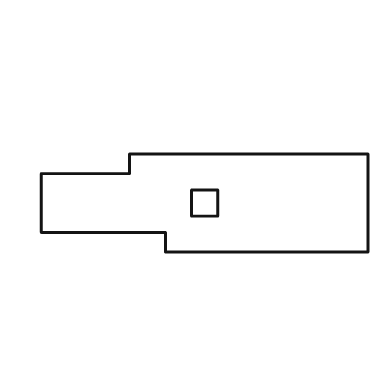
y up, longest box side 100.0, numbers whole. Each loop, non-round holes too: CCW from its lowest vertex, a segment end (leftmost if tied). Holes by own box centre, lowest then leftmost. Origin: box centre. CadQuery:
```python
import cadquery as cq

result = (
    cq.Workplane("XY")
    .moveTo(-12.0, -15.0)
    .lineTo(50.0, -15.0)
    .lineTo(50.0, 15.0)
    .lineTo(-23.0, 15.0)
    .lineTo(-23.0, 9.0)
    .lineTo(-50.0, 9.0)
    .lineTo(-50.0, -9.0)
    .lineTo(-12.0, -9.0)
    .close()
    .moveTo(-4.0, -4.0)
    .lineTo(4.0, -4.0)
    .lineTo(4.0, 4.0)
    .lineTo(-4.0, 4.0)
    .close()
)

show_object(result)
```